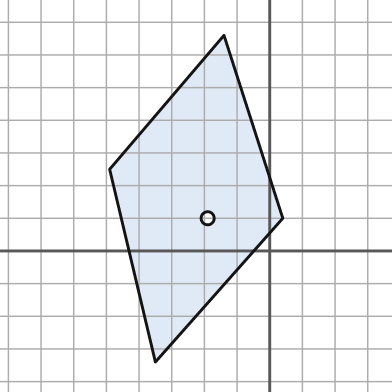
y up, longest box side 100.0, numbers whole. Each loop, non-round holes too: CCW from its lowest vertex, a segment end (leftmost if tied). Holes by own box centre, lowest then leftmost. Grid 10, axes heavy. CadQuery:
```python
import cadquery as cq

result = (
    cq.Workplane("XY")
    .moveTo(-35.0, -34.0)
    .lineTo(4.0, 10.0)
    .lineTo(-14.0, 66.0)
    .lineTo(-49.0, 25.0)
    .close()
    .moveTo(-19.0, 10.0)
    .circle(2.0)
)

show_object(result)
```